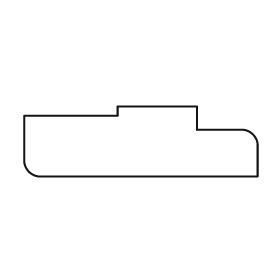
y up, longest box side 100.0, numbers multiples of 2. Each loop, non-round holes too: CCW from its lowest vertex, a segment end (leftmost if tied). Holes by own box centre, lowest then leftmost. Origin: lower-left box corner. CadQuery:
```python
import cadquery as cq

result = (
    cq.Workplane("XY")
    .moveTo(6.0, 0.0)
    .lineTo(100.0, 0.0)
    .lineTo(100.0, 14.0)
    .threePointArc((98.0, 18.0), (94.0, 20.0))
    .lineTo(74.0, 20.0)
    .lineTo(74.0, 30.0)
    .lineTo(40.0, 30.0)
    .lineTo(40.0, 26.0)
    .lineTo(0.0, 26.0)
    .lineTo(0.0, 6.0)
    .threePointArc((2.0, 2.0), (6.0, 0.0))
    .close()
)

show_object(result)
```